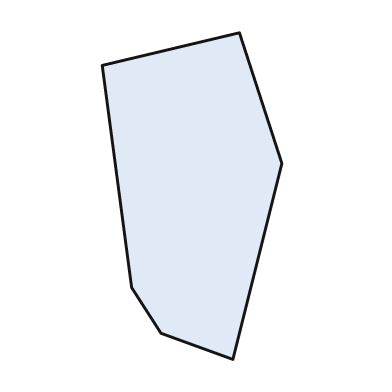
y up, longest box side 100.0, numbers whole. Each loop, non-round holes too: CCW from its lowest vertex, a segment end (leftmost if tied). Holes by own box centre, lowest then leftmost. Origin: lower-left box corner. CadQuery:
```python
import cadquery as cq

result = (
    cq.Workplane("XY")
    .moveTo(40.0, 0.0)
    .lineTo(55.0, 60.0)
    .lineTo(42.0, 100.0)
    .lineTo(0.0, 90.0)
    .lineTo(9.0, 22.0)
    .lineTo(18.0, 8.0)
    .close()
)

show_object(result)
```